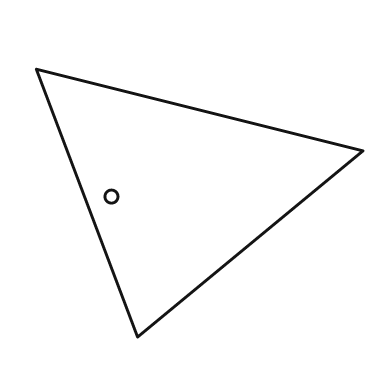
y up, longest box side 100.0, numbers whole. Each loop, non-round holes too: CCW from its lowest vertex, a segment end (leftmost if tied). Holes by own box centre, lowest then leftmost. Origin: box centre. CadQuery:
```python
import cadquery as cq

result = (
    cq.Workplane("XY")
    .moveTo(-19.0, -41.0)
    .lineTo(50.0, 16.0)
    .lineTo(-50.0, 41.0)
    .close()
    .moveTo(-27.0, 2.0)
    .circle(2.0)
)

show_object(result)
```